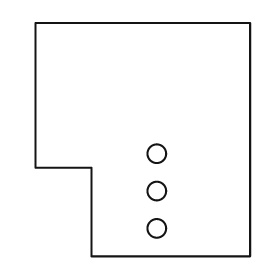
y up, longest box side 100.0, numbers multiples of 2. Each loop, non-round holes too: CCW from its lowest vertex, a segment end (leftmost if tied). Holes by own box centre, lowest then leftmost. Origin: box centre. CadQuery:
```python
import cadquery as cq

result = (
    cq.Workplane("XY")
    .moveTo(-22.0, -50.0)
    .lineTo(46.0, -50.0)
    .lineTo(46.0, 50.0)
    .lineTo(-46.0, 50.0)
    .lineTo(-46.0, -12.0)
    .lineTo(-22.0, -12.0)
    .close()
    .moveTo(6.0, -38.0)
    .circle(4.0)
    .moveTo(6.0, -22.0)
    .circle(4.0)
    .moveTo(6.0, -6.0)
    .circle(4.0)
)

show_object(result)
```